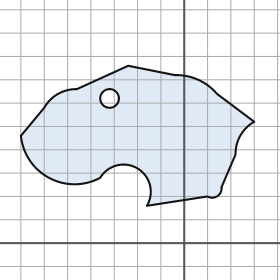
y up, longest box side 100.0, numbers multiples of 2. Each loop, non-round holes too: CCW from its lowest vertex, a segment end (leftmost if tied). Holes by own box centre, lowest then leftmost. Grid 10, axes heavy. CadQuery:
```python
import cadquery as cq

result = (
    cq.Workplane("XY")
    .moveTo(-16.0, 16.0)
    .lineTo(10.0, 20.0)
    .threePointArc((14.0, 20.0), (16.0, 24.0))
    .lineTo(22.0, 38.0)
    .threePointArc((24.0, 46.0), (30.0, 52.0))
    .lineTo(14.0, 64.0)
    .threePointArc((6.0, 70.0), (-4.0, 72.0))
    .lineTo(-24.0, 76.0)
    .lineTo(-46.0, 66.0)
    .threePointArc((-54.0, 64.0), (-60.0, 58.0))
    .lineTo(-70.0, 46.0)
    .threePointArc((-58.0, 28.0), (-36.0, 28.0))
    .threePointArc((-20.0, 32.0), (-16.0, 16.0))
    .close()
    .moveTo(-32.0, 62.0)
    .circle(4.0)
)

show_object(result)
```